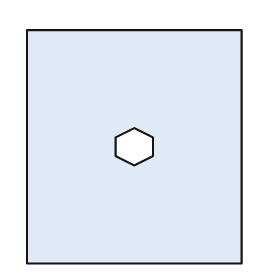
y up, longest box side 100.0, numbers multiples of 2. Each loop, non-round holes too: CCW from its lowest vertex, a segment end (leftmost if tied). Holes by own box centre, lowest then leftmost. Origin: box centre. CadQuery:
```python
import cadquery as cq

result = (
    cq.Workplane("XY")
    .moveTo(-46.0, -50.0)
    .lineTo(46.0, -50.0)
    .lineTo(46.0, 50.0)
    .lineTo(-46.0, 50.0)
    .close()
    .moveTo(0.0, -8.0)
    .lineTo(8.0, -4.0)
    .lineTo(8.0, 4.0)
    .lineTo(0.0, 8.0)
    .lineTo(-8.0, 4.0)
    .lineTo(-8.0, -4.0)
    .close()
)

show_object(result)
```